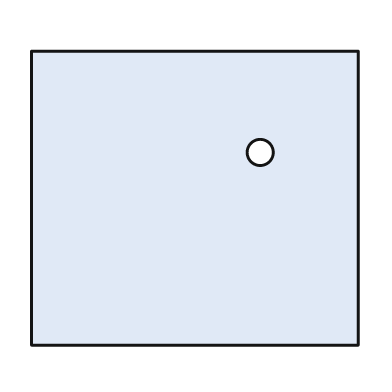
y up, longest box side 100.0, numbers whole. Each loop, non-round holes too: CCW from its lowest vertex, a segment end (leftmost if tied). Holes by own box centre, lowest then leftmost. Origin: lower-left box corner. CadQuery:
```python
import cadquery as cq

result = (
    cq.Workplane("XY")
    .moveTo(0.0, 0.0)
    .lineTo(100.0, 0.0)
    .lineTo(100.0, 90.0)
    .lineTo(0.0, 90.0)
    .close()
    .moveTo(70.0, 59.0)
    .circle(4.0)
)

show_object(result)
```